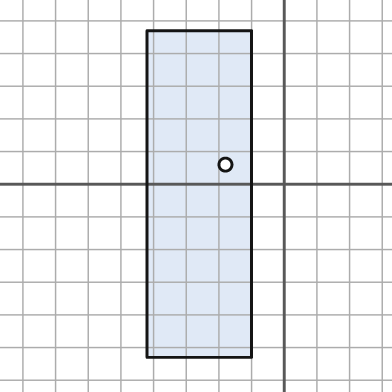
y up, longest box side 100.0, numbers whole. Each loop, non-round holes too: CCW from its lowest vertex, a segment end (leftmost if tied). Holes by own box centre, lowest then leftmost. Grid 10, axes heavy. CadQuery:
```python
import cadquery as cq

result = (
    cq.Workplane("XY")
    .moveTo(-42.0, -53.0)
    .lineTo(-10.0, -53.0)
    .lineTo(-10.0, 47.0)
    .lineTo(-42.0, 47.0)
    .close()
    .moveTo(-18.0, 6.0)
    .circle(2.0)
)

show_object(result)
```